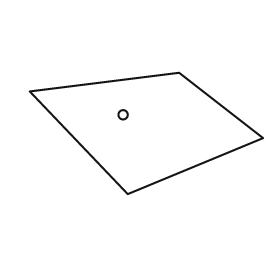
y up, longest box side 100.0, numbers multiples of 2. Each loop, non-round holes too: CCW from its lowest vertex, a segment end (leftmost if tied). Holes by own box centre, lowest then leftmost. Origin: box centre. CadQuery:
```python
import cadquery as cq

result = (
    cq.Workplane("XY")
    .moveTo(-8.0, -26.0)
    .lineTo(50.0, -2.0)
    .lineTo(14.0, 26.0)
    .lineTo(-50.0, 18.0)
    .close()
    .moveTo(-10.0, 8.0)
    .circle(2.0)
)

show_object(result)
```